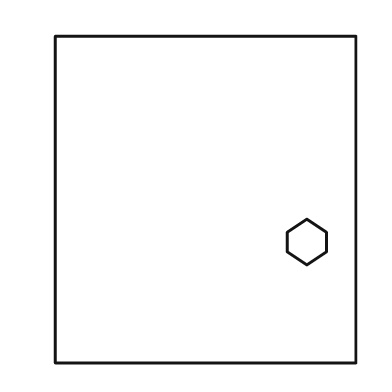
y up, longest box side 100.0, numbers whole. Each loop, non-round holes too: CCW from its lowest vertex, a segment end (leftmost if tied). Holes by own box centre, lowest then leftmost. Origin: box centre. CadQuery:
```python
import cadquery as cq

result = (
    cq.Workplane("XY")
    .moveTo(-46.0, -50.0)
    .lineTo(46.0, -50.0)
    .lineTo(46.0, 50.0)
    .lineTo(-46.0, 50.0)
    .close()
    .moveTo(31.0, -20.0)
    .lineTo(37.0, -16.0)
    .lineTo(37.0, -10.0)
    .lineTo(31.0, -6.0)
    .lineTo(25.0, -10.0)
    .lineTo(25.0, -16.0)
    .close()
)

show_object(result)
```